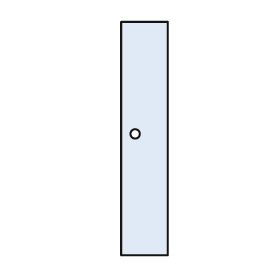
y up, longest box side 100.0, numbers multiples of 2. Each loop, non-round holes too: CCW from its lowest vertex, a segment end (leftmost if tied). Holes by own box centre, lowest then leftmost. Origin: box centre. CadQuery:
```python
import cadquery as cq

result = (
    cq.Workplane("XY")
    .moveTo(-10.0, -50.0)
    .lineTo(10.0, -50.0)
    .lineTo(10.0, 50.0)
    .lineTo(-10.0, 50.0)
    .close()
    .moveTo(-4.0, 2.0)
    .circle(2.0)
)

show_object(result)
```